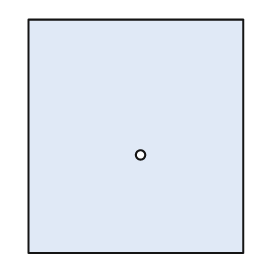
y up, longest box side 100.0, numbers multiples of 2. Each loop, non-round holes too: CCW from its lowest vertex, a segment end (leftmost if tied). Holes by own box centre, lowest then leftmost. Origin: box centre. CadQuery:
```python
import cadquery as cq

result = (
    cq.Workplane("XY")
    .moveTo(-46.0, -50.0)
    .lineTo(46.0, -50.0)
    .lineTo(46.0, 50.0)
    .lineTo(-46.0, 50.0)
    .close()
    .moveTo(2.0, -8.0)
    .circle(2.0)
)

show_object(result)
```